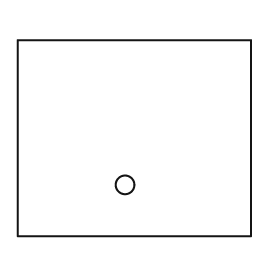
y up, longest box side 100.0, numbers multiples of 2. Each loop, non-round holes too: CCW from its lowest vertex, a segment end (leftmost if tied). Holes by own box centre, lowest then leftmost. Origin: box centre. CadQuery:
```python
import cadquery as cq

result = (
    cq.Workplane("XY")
    .moveTo(-50.0, -42.0)
    .lineTo(50.0, -42.0)
    .lineTo(50.0, 42.0)
    .lineTo(-50.0, 42.0)
    .close()
    .moveTo(-4.0, -20.0)
    .circle(4.0)
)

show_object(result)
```